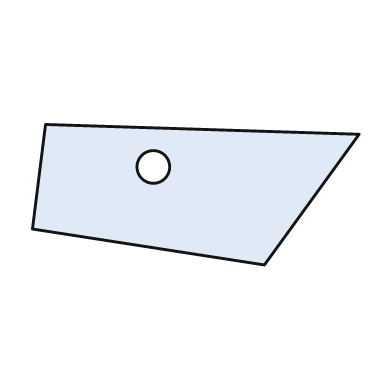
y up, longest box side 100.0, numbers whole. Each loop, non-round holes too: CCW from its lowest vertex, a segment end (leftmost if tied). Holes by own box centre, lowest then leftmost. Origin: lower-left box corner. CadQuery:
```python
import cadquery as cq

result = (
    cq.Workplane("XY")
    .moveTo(71.0, 0.0)
    .lineTo(100.0, 40.0)
    .lineTo(4.0, 43.0)
    .lineTo(0.0, 11.0)
    .close()
    .moveTo(37.0, 30.0)
    .circle(5.0)
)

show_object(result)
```